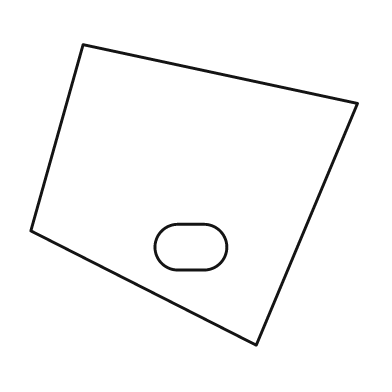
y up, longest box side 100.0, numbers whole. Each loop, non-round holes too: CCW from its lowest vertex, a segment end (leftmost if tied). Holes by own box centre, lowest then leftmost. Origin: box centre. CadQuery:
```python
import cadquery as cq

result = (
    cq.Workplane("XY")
    .moveTo(19.0, -46.0)
    .lineTo(50.0, 28.0)
    .lineTo(-34.0, 46.0)
    .lineTo(-50.0, -11.0)
    .close()
    .moveTo(-5.0, -23.0)
    .lineTo(3.0, -23.0)
    .threePointArc((10.0, -16.0), (3.0, -9.0))
    .lineTo(-5.0, -9.0)
    .threePointArc((-12.0, -16.0), (-5.0, -23.0))
    .close()
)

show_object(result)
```